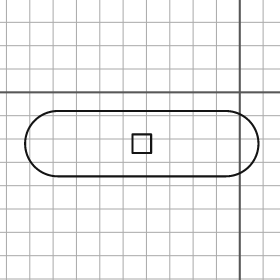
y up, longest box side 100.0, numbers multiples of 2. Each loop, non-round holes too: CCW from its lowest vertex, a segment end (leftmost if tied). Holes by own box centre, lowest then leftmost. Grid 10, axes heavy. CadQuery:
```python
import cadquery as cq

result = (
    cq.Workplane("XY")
    .moveTo(-78.0, -36.0)
    .lineTo(-6.0, -36.0)
    .threePointArc((8.0, -22.0), (-6.0, -8.0))
    .lineTo(-78.0, -8.0)
    .threePointArc((-92.0, -22.0), (-78.0, -36.0))
    .close()
    .moveTo(-46.0, -26.0)
    .lineTo(-38.0, -26.0)
    .lineTo(-38.0, -18.0)
    .lineTo(-46.0, -18.0)
    .close()
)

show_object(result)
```